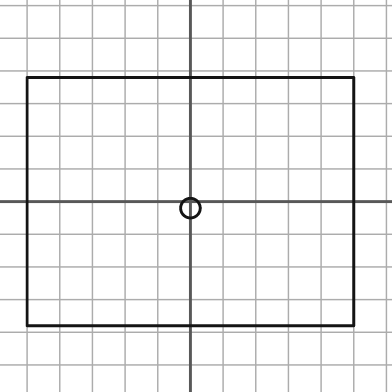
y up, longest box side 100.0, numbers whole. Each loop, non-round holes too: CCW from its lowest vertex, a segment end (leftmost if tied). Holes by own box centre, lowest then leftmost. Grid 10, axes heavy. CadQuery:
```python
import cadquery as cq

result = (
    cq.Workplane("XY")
    .moveTo(-50.0, -38.0)
    .lineTo(50.0, -38.0)
    .lineTo(50.0, 38.0)
    .lineTo(-50.0, 38.0)
    .close()
    .moveTo(0.0, -2.0)
    .circle(3.0)
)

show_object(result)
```